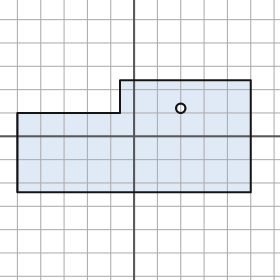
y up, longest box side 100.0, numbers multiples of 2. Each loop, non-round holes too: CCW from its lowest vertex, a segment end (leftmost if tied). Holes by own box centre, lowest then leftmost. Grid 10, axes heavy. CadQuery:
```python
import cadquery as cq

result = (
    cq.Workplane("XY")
    .moveTo(-50.0, -24.0)
    .lineTo(50.0, -24.0)
    .lineTo(50.0, 24.0)
    .lineTo(-6.0, 24.0)
    .lineTo(-6.0, 10.0)
    .lineTo(-50.0, 10.0)
    .close()
    .moveTo(20.0, 12.0)
    .circle(2.0)
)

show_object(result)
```